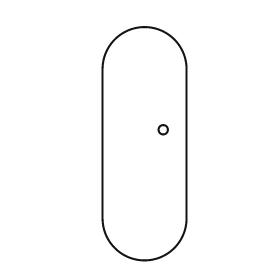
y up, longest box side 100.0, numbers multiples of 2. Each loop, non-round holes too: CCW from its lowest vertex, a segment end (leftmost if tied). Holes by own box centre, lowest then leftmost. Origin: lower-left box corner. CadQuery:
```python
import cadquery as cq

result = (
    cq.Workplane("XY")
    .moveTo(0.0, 18.0)
    .threePointArc((18.0, 0.0), (36.0, 18.0))
    .lineTo(36.0, 82.0)
    .threePointArc((18.0, 100.0), (0.0, 82.0))
    .close()
    .moveTo(26.0, 56.0)
    .circle(2.0)
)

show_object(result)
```